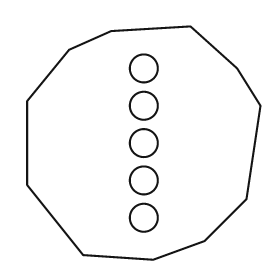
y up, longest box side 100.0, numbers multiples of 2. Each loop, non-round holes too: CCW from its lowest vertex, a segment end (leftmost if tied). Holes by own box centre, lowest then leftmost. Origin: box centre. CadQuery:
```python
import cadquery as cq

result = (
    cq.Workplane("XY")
    .moveTo(4.0, -50.0)
    .lineTo(26.0, -42.0)
    .lineTo(44.0, -24.0)
    .lineTo(50.0, 16.0)
    .lineTo(40.0, 32.0)
    .lineTo(20.0, 50.0)
    .lineTo(-14.0, 48.0)
    .lineTo(-32.0, 40.0)
    .lineTo(-50.0, 18.0)
    .lineTo(-50.0, -18.0)
    .lineTo(-26.0, -48.0)
    .close()
    .moveTo(0.0, -32.0)
    .circle(6.0)
    .moveTo(0.0, -16.0)
    .circle(6.0)
    .moveTo(0.0, 0.0)
    .circle(6.0)
    .moveTo(0.0, 16.0)
    .circle(6.0)
    .moveTo(0.0, 32.0)
    .circle(6.0)
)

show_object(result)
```